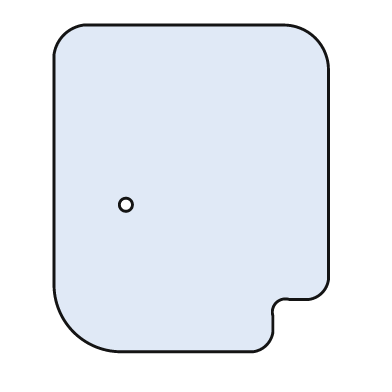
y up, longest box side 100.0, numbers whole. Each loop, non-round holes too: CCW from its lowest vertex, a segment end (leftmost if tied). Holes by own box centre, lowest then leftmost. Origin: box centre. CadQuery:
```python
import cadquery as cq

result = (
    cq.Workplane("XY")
    .moveTo(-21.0, -50.0)
    .lineTo(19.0, -50.0)
    .threePointArc((23.0, -48.0), (25.0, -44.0))
    .lineTo(25.0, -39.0)
    .threePointArc((26.0, -35.0), (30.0, -34.0))
    .lineTo(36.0, -34.0)
    .threePointArc((40.0, -32.0), (42.0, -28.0))
    .lineTo(42.0, 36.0)
    .threePointArc((38.0, 46.0), (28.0, 50.0))
    .lineTo(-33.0, 50.0)
    .threePointArc((-39.0, 47.0), (-42.0, 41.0))
    .lineTo(-42.0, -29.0)
    .threePointArc((-36.0, -44.0), (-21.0, -50.0))
    .close()
    .moveTo(-20.0, -5.0)
    .circle(2.0)
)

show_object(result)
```